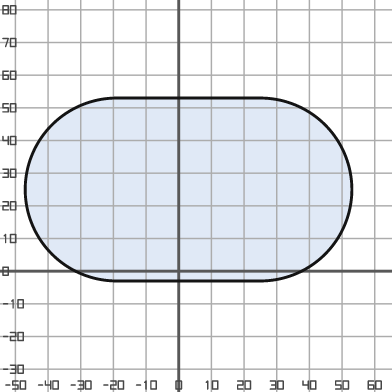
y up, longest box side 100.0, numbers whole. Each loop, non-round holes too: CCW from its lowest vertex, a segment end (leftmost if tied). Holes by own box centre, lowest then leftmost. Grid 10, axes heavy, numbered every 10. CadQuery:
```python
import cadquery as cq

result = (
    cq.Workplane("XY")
    .moveTo(-19.0, -3.0)
    .lineTo(25.0, -3.0)
    .threePointArc((53.0, 25.0), (25.0, 53.0))
    .lineTo(-19.0, 53.0)
    .threePointArc((-47.0, 25.0), (-19.0, -3.0))
    .close()
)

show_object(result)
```